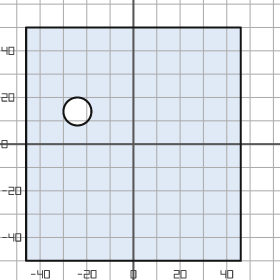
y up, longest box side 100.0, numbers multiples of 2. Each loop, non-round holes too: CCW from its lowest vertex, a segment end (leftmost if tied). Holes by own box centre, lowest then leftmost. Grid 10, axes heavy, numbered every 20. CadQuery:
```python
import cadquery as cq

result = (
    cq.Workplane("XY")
    .moveTo(-46.0, -50.0)
    .lineTo(46.0, -50.0)
    .lineTo(46.0, 50.0)
    .lineTo(-46.0, 50.0)
    .close()
    .moveTo(-24.0, 14.0)
    .circle(6.0)
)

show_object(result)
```